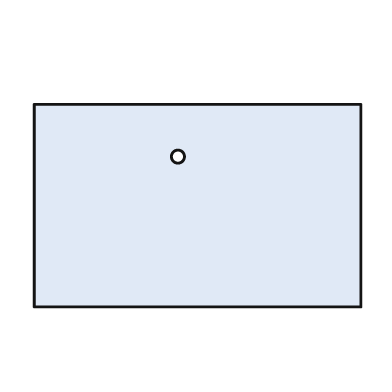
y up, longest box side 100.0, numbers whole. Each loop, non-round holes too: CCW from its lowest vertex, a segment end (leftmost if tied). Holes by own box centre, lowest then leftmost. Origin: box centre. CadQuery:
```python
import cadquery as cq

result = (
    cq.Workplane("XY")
    .moveTo(-50.0, -31.0)
    .lineTo(50.0, -31.0)
    .lineTo(50.0, 31.0)
    .lineTo(-50.0, 31.0)
    .close()
    .moveTo(-6.0, 15.0)
    .circle(2.0)
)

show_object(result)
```